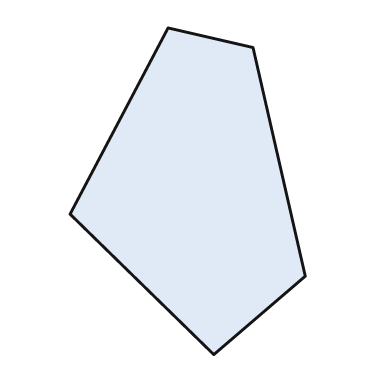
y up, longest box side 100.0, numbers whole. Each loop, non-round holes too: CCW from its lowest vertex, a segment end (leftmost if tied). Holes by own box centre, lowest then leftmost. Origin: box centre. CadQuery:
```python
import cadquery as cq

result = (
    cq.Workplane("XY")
    .moveTo(8.0, -50.0)
    .lineTo(36.0, -26.0)
    .lineTo(20.0, 44.0)
    .lineTo(-6.0, 50.0)
    .lineTo(-36.0, -7.0)
    .close()
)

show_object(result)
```